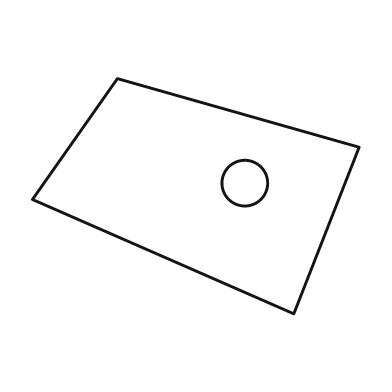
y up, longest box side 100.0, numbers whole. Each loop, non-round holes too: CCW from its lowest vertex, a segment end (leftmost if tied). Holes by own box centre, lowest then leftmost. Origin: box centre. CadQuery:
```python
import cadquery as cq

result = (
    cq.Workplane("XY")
    .moveTo(30.0, -36.0)
    .lineTo(50.0, 15.0)
    .lineTo(-24.0, 36.0)
    .lineTo(-50.0, -1.0)
    .close()
    .moveTo(15.0, 4.0)
    .circle(7.0)
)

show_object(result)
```